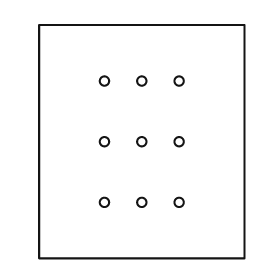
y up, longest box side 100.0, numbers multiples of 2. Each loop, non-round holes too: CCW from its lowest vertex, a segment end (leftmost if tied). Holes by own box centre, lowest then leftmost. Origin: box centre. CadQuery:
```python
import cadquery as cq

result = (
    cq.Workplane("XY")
    .moveTo(-44.0, -50.0)
    .lineTo(44.0, -50.0)
    .lineTo(44.0, 50.0)
    .lineTo(-44.0, 50.0)
    .close()
    .moveTo(-16.0, -26.0)
    .circle(2.0)
    .moveTo(0.0, -26.0)
    .circle(2.0)
    .moveTo(16.0, -26.0)
    .circle(2.0)
    .moveTo(-16.0, 0.0)
    .circle(2.0)
    .moveTo(0.0, 0.0)
    .circle(2.0)
    .moveTo(16.0, 0.0)
    .circle(2.0)
    .moveTo(-16.0, 26.0)
    .circle(2.0)
    .moveTo(0.0, 26.0)
    .circle(2.0)
    .moveTo(16.0, 26.0)
    .circle(2.0)
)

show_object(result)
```